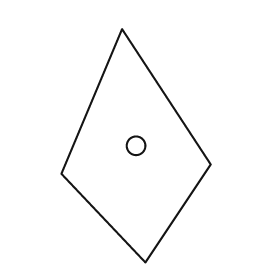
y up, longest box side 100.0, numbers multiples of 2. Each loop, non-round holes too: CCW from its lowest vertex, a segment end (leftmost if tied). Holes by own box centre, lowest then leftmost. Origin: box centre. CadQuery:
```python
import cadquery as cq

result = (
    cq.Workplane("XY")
    .moveTo(4.0, -50.0)
    .lineTo(32.0, -8.0)
    .lineTo(-6.0, 50.0)
    .lineTo(-32.0, -12.0)
    .close()
    .moveTo(0.0, 0.0)
    .circle(4.0)
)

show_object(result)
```